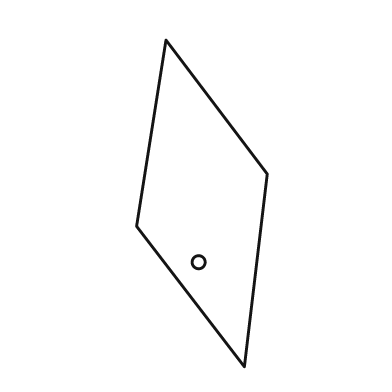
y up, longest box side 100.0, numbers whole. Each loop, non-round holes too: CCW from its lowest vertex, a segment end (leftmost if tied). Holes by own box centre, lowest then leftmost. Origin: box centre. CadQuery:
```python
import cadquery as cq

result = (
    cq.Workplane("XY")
    .moveTo(13.0, -50.0)
    .lineTo(20.0, 9.0)
    .lineTo(-11.0, 50.0)
    .lineTo(-20.0, -7.0)
    .close()
    .moveTo(-1.0, -18.0)
    .circle(2.0)
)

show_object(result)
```